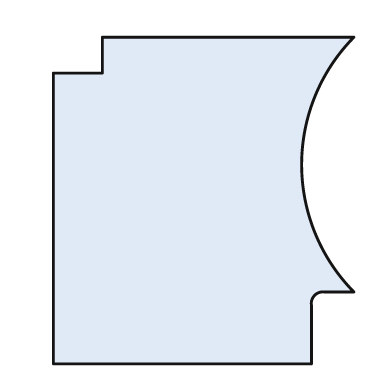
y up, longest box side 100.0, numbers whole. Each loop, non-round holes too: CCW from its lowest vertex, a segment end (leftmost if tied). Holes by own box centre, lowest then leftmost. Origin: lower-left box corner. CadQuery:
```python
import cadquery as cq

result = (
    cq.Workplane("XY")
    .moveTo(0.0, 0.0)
    .lineTo(79.0, 0.0)
    .lineTo(79.0, 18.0)
    .threePointArc((80.0, 21.0), (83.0, 22.0))
    .lineTo(92.0, 22.0)
    .threePointArc((76.0, 61.0), (92.0, 100.0))
    .lineTo(15.0, 100.0)
    .lineTo(15.0, 89.0)
    .lineTo(0.0, 89.0)
    .close()
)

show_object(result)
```